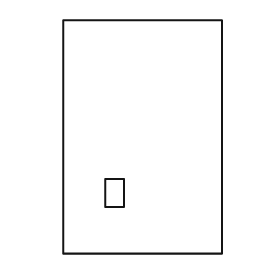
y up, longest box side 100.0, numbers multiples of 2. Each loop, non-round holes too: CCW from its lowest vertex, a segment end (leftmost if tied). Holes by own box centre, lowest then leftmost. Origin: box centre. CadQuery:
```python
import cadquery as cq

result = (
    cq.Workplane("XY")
    .moveTo(-34.0, -50.0)
    .lineTo(34.0, -50.0)
    .lineTo(34.0, 50.0)
    .lineTo(-34.0, 50.0)
    .close()
    .moveTo(-16.0, -30.0)
    .lineTo(-8.0, -30.0)
    .lineTo(-8.0, -18.0)
    .lineTo(-16.0, -18.0)
    .close()
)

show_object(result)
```